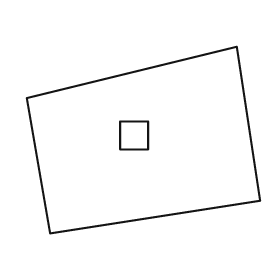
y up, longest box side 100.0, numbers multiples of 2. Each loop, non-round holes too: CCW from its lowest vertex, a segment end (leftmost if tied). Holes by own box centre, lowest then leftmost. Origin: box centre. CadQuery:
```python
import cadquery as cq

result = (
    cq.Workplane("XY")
    .moveTo(-40.0, -40.0)
    .lineTo(50.0, -26.0)
    .lineTo(40.0, 40.0)
    .lineTo(-50.0, 18.0)
    .close()
    .moveTo(-10.0, -4.0)
    .lineTo(2.0, -4.0)
    .lineTo(2.0, 8.0)
    .lineTo(-10.0, 8.0)
    .close()
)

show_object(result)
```